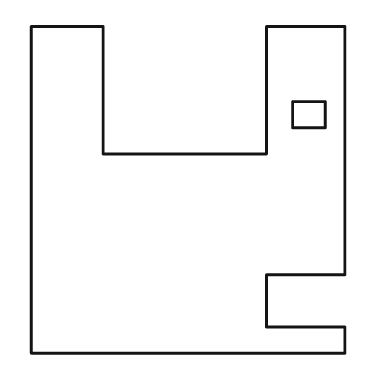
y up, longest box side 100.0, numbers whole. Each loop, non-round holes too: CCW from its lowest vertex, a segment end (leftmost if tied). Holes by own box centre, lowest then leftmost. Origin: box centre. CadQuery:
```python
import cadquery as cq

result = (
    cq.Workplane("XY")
    .moveTo(-48.0, -50.0)
    .lineTo(48.0, -50.0)
    .lineTo(48.0, -42.0)
    .lineTo(24.0, -42.0)
    .lineTo(24.0, -26.0)
    .lineTo(48.0, -26.0)
    .lineTo(48.0, 50.0)
    .lineTo(24.0, 50.0)
    .lineTo(24.0, 11.0)
    .lineTo(-26.0, 11.0)
    .lineTo(-26.0, 50.0)
    .lineTo(-48.0, 50.0)
    .close()
    .moveTo(32.0, 19.0)
    .lineTo(42.0, 19.0)
    .lineTo(42.0, 27.0)
    .lineTo(32.0, 27.0)
    .close()
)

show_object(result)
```